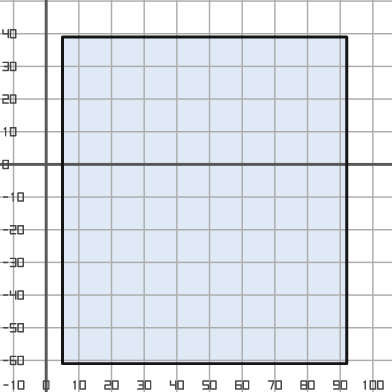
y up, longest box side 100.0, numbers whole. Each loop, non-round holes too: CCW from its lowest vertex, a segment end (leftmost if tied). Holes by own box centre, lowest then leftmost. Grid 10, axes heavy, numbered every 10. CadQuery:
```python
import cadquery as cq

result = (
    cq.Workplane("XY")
    .moveTo(5.0, -61.0)
    .lineTo(92.0, -61.0)
    .lineTo(92.0, 39.0)
    .lineTo(5.0, 39.0)
    .close()
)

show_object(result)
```